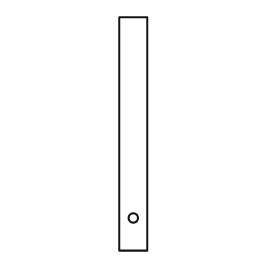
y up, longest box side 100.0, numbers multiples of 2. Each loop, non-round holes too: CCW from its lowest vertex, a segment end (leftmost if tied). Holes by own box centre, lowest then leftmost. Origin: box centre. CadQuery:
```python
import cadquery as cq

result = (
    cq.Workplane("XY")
    .moveTo(-6.0, -50.0)
    .lineTo(6.0, -50.0)
    .lineTo(6.0, 50.0)
    .lineTo(-6.0, 50.0)
    .close()
    .moveTo(0.0, -36.0)
    .circle(2.0)
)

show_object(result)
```